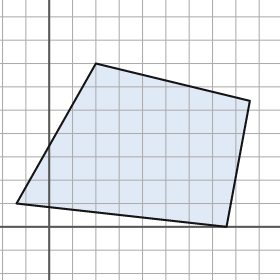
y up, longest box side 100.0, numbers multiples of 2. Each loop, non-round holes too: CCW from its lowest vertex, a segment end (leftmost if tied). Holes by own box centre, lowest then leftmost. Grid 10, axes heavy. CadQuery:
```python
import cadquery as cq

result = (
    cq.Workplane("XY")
    .moveTo(76.0, 0.0)
    .lineTo(86.0, 54.0)
    .lineTo(20.0, 70.0)
    .lineTo(-14.0, 10.0)
    .close()
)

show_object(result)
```